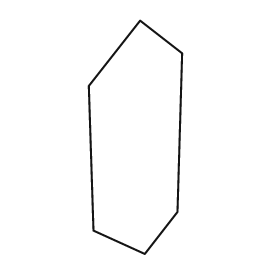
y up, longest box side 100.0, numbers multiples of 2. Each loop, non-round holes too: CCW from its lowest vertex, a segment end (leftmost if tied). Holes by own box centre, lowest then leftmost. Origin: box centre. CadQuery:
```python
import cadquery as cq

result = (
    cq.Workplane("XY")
    .moveTo(4.0, -50.0)
    .lineTo(18.0, -32.0)
    .lineTo(20.0, 36.0)
    .lineTo(2.0, 50.0)
    .lineTo(-20.0, 22.0)
    .lineTo(-18.0, -40.0)
    .close()
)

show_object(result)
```